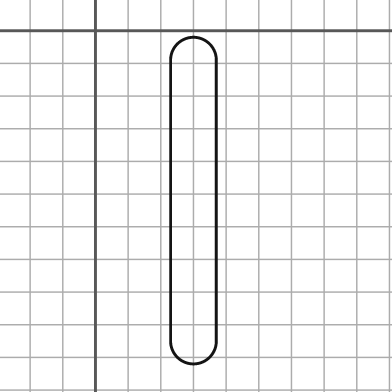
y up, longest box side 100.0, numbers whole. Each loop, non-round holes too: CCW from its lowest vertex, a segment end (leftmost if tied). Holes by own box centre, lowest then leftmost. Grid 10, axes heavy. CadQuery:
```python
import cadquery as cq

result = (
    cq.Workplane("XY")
    .moveTo(23.0, -95.0)
    .threePointArc((30.0, -102.0), (37.0, -95.0))
    .lineTo(37.0, -9.0)
    .threePointArc((30.0, -2.0), (23.0, -9.0))
    .close()
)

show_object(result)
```